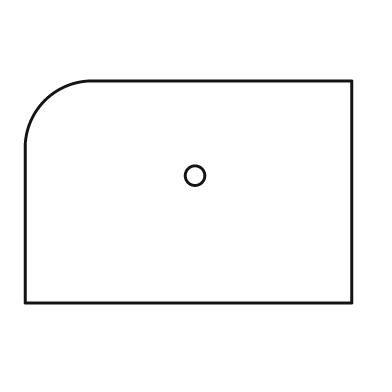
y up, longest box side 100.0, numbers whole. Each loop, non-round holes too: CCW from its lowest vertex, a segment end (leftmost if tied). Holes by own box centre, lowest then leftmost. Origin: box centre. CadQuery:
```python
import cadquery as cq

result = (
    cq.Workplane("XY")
    .moveTo(-50.0, -34.0)
    .lineTo(50.0, -34.0)
    .lineTo(50.0, 34.0)
    .lineTo(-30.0, 34.0)
    .threePointArc((-44.0, 28.0), (-50.0, 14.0))
    .close()
    .moveTo(2.0, 5.0)
    .circle(3.0)
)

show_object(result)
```